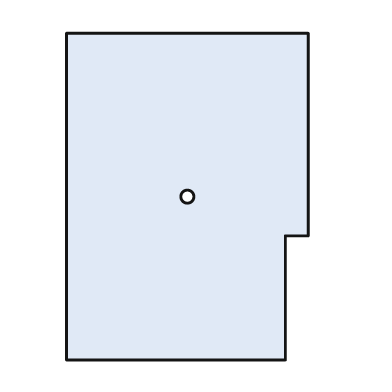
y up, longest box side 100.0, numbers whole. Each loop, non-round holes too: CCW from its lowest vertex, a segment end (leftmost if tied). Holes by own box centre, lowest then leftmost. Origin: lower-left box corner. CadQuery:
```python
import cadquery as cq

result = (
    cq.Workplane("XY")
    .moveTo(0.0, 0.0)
    .lineTo(67.0, 0.0)
    .lineTo(67.0, 38.0)
    .lineTo(74.0, 38.0)
    .lineTo(74.0, 100.0)
    .lineTo(0.0, 100.0)
    .close()
    .moveTo(37.0, 50.0)
    .circle(2.0)
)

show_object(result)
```